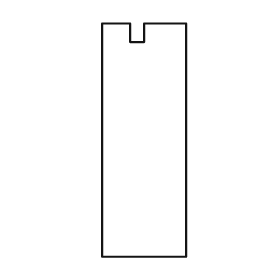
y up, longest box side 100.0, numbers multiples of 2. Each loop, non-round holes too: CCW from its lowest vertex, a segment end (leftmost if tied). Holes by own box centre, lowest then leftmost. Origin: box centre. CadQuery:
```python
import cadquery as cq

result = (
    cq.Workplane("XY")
    .moveTo(-18.0, -50.0)
    .lineTo(18.0, -50.0)
    .lineTo(18.0, 50.0)
    .lineTo(0.0, 50.0)
    .lineTo(0.0, 42.0)
    .lineTo(-6.0, 42.0)
    .lineTo(-6.0, 50.0)
    .lineTo(-18.0, 50.0)
    .close()
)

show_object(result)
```